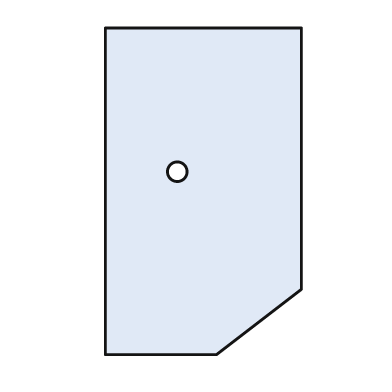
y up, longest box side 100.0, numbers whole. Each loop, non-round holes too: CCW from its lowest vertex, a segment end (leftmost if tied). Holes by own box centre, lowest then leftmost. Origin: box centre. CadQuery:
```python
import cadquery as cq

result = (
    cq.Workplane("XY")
    .moveTo(-30.0, -50.0)
    .lineTo(4.0, -50.0)
    .lineTo(30.0, -30.0)
    .lineTo(30.0, 50.0)
    .lineTo(-30.0, 50.0)
    .close()
    .moveTo(-8.0, 6.0)
    .circle(3.0)
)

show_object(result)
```